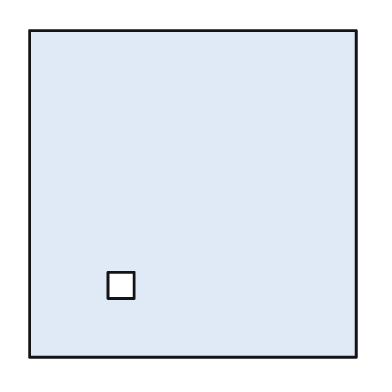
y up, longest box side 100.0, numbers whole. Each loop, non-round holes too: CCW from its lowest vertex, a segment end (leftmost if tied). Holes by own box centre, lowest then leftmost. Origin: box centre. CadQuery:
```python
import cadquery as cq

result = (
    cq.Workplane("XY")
    .moveTo(-50.0, -50.0)
    .lineTo(50.0, -50.0)
    .lineTo(50.0, 50.0)
    .lineTo(-50.0, 50.0)
    .close()
    .moveTo(-26.0, -32.0)
    .lineTo(-18.0, -32.0)
    .lineTo(-18.0, -24.0)
    .lineTo(-26.0, -24.0)
    .close()
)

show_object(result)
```